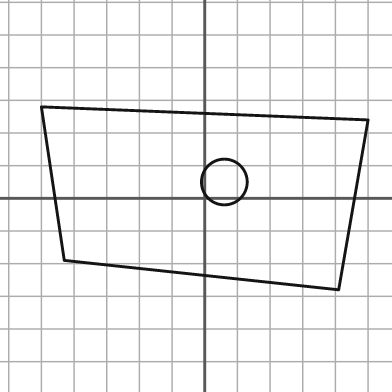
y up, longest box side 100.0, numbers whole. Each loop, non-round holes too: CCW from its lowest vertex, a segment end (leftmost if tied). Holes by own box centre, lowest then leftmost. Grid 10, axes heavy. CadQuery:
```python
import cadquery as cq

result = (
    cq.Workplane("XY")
    .moveTo(41.0, -28.0)
    .lineTo(50.0, 24.0)
    .lineTo(-50.0, 28.0)
    .lineTo(-43.0, -19.0)
    .close()
    .moveTo(6.0, 5.0)
    .circle(7.0)
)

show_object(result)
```